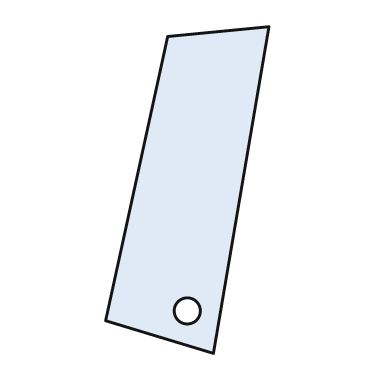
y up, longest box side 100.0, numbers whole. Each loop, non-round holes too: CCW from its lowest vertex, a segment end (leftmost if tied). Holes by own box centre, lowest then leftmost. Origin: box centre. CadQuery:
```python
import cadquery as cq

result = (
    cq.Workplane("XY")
    .moveTo(8.0, -50.0)
    .lineTo(25.0, 50.0)
    .lineTo(-6.0, 47.0)
    .lineTo(-25.0, -40.0)
    .close()
    .moveTo(0.0, -37.0)
    .circle(4.0)
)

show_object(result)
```